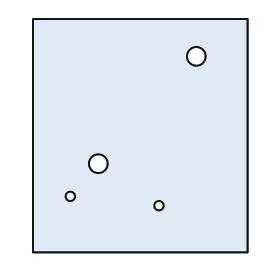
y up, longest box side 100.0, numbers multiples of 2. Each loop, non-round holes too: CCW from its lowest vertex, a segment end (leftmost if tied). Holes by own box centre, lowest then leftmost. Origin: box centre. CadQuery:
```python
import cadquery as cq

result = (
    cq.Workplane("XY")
    .moveTo(-46.0, -50.0)
    .lineTo(46.0, -50.0)
    .lineTo(46.0, 50.0)
    .lineTo(-46.0, 50.0)
    .close()
    .moveTo(8.0, -30.0)
    .circle(2.0)
    .moveTo(-30.0, -26.0)
    .circle(2.0)
    .moveTo(-18.0, -12.0)
    .circle(4.0)
    .moveTo(24.0, 34.0)
    .circle(4.0)
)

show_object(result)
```